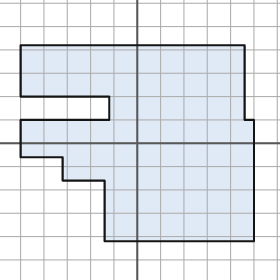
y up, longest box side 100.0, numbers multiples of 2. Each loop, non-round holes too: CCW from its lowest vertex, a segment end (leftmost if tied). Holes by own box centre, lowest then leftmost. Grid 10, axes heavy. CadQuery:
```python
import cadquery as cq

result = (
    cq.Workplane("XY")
    .moveTo(-14.0, -42.0)
    .lineTo(50.0, -42.0)
    .lineTo(50.0, 10.0)
    .lineTo(46.0, 10.0)
    .lineTo(46.0, 42.0)
    .lineTo(-50.0, 42.0)
    .lineTo(-50.0, 20.0)
    .lineTo(-12.0, 20.0)
    .lineTo(-12.0, 10.0)
    .lineTo(-50.0, 10.0)
    .lineTo(-50.0, -6.0)
    .lineTo(-32.0, -6.0)
    .lineTo(-32.0, -16.0)
    .lineTo(-14.0, -16.0)
    .close()
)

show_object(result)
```